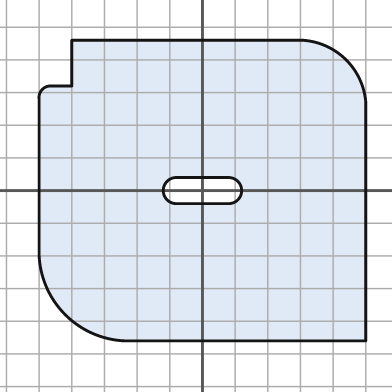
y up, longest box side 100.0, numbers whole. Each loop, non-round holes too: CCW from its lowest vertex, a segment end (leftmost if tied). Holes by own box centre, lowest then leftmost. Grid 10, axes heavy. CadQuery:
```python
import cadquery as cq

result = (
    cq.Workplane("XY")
    .moveTo(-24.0, -46.0)
    .lineTo(50.0, -46.0)
    .lineTo(50.0, 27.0)
    .threePointArc((44.0, 40.0), (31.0, 46.0))
    .lineTo(-40.0, 46.0)
    .lineTo(-40.0, 32.0)
    .lineTo(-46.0, 32.0)
    .threePointArc((-49.0, 31.0), (-50.0, 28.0))
    .lineTo(-50.0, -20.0)
    .threePointArc((-42.0, -38.0), (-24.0, -46.0))
    .close()
    .moveTo(-8.0, -4.0)
    .lineTo(8.0, -4.0)
    .threePointArc((12.0, 0.0), (8.0, 4.0))
    .lineTo(-8.0, 4.0)
    .threePointArc((-12.0, 0.0), (-8.0, -4.0))
    .close()
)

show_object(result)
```